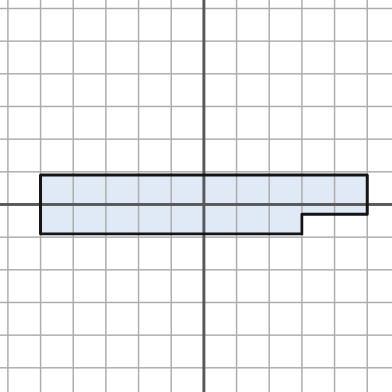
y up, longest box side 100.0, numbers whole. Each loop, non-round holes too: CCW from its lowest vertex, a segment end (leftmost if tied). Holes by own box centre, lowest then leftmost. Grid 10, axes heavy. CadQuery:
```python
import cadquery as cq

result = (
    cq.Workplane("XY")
    .moveTo(-50.0, -9.0)
    .lineTo(30.0, -9.0)
    .lineTo(30.0, -3.0)
    .lineTo(50.0, -3.0)
    .lineTo(50.0, 9.0)
    .lineTo(-50.0, 9.0)
    .close()
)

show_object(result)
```